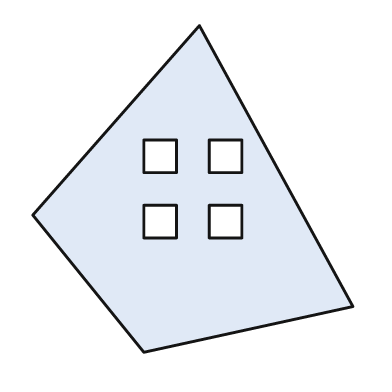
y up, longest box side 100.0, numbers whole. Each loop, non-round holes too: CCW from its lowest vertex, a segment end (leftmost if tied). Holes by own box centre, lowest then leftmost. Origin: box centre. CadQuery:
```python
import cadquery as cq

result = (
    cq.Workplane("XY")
    .moveTo(-15.0, -50.0)
    .lineTo(49.0, -36.0)
    .lineTo(2.0, 50.0)
    .lineTo(-49.0, -8.0)
    .close()
    .moveTo(-15.0, -15.0)
    .lineTo(-5.0, -15.0)
    .lineTo(-5.0, -5.0)
    .lineTo(-15.0, -5.0)
    .close()
    .moveTo(5.0, -15.0)
    .lineTo(15.0, -15.0)
    .lineTo(15.0, -5.0)
    .lineTo(5.0, -5.0)
    .close()
    .moveTo(-15.0, 5.0)
    .lineTo(-5.0, 5.0)
    .lineTo(-5.0, 15.0)
    .lineTo(-15.0, 15.0)
    .close()
    .moveTo(5.0, 5.0)
    .lineTo(15.0, 5.0)
    .lineTo(15.0, 15.0)
    .lineTo(5.0, 15.0)
    .close()
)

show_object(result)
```